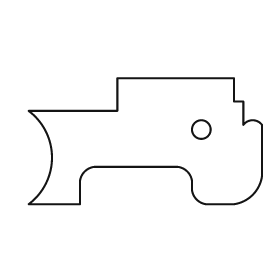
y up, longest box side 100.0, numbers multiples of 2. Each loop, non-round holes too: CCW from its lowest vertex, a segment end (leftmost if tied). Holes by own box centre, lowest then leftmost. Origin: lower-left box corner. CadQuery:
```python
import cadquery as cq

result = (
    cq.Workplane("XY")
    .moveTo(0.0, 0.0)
    .lineTo(22.0, 0.0)
    .lineTo(22.0, 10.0)
    .threePointArc((24.0, 14.0), (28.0, 16.0))
    .lineTo(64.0, 16.0)
    .threePointArc((68.0, 14.0), (70.0, 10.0))
    .lineTo(70.0, 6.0)
    .threePointArc((72.0, 2.0), (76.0, 0.0))
    .lineTo(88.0, 0.0)
    .threePointArc((96.0, 4.0), (100.0, 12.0))
    .lineTo(100.0, 34.0)
    .threePointArc((96.0, 36.0), (92.0, 34.0))
    .lineTo(92.0, 44.0)
    .lineTo(88.0, 44.0)
    .lineTo(88.0, 54.0)
    .lineTo(38.0, 54.0)
    .lineTo(38.0, 40.0)
    .lineTo(0.0, 40.0)
    .threePointArc((10.0, 20.0), (0.0, 0.0))
    .close()
    .moveTo(74.0, 32.0)
    .circle(4.0)
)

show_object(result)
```